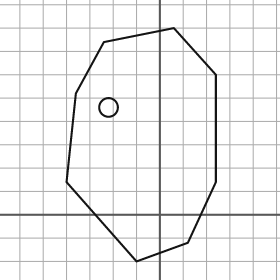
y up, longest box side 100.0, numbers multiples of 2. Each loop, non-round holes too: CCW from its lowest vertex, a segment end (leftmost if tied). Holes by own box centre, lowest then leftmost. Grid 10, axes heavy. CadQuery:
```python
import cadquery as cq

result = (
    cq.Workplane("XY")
    .moveTo(-10.0, -20.0)
    .lineTo(12.0, -12.0)
    .lineTo(24.0, 14.0)
    .lineTo(24.0, 60.0)
    .lineTo(6.0, 80.0)
    .lineTo(-24.0, 74.0)
    .lineTo(-36.0, 52.0)
    .lineTo(-40.0, 14.0)
    .close()
    .moveTo(-22.0, 46.0)
    .circle(4.0)
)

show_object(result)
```